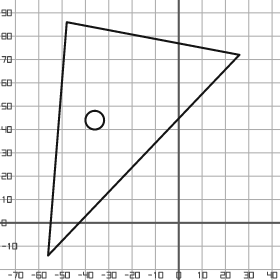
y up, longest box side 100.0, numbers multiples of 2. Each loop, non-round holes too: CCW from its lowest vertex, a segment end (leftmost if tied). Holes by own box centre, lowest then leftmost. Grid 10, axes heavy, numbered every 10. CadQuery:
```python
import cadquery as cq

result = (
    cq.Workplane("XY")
    .moveTo(-56.0, -14.0)
    .lineTo(26.0, 72.0)
    .lineTo(-48.0, 86.0)
    .close()
    .moveTo(-36.0, 44.0)
    .circle(4.0)
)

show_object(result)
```